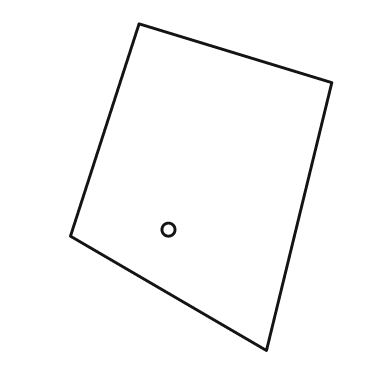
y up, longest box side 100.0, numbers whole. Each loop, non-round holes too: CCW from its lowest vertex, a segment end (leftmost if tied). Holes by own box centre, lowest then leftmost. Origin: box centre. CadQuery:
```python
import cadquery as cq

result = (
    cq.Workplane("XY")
    .moveTo(20.0, -50.0)
    .lineTo(40.0, 32.0)
    .lineTo(-19.0, 50.0)
    .lineTo(-40.0, -15.0)
    .close()
    .moveTo(-10.0, -13.0)
    .circle(2.0)
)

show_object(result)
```